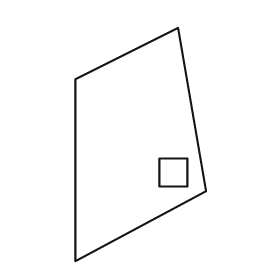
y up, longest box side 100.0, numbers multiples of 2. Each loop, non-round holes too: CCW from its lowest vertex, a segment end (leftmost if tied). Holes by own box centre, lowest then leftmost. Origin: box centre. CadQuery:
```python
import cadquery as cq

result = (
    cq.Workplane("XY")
    .moveTo(-28.0, -50.0)
    .lineTo(28.0, -20.0)
    .lineTo(16.0, 50.0)
    .lineTo(-28.0, 28.0)
    .close()
    .moveTo(8.0, -18.0)
    .lineTo(20.0, -18.0)
    .lineTo(20.0, -6.0)
    .lineTo(8.0, -6.0)
    .close()
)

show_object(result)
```